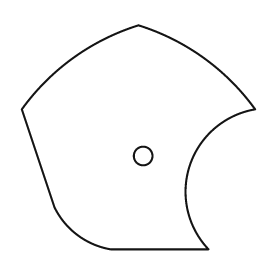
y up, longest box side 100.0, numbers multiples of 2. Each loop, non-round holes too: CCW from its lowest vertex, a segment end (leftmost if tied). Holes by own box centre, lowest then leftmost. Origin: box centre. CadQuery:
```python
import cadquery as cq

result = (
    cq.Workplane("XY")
    .moveTo(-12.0, -48.0)
    .lineTo(30.0, -48.0)
    .threePointArc((22.0, -12.0), (50.0, 12.0))
    .threePointArc((28.0, 34.0), (0.0, 48.0))
    .threePointArc((-28.0, 34.0), (-50.0, 12.0))
    .lineTo(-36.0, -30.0)
    .threePointArc((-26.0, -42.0), (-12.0, -48.0))
    .close()
    .moveTo(2.0, -8.0)
    .circle(4.0)
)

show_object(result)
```